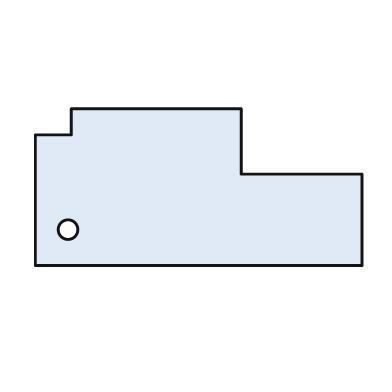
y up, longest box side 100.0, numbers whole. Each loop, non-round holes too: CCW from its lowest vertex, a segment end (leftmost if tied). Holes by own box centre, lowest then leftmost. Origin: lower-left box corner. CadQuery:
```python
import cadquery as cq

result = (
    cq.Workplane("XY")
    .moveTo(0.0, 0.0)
    .lineTo(100.0, 0.0)
    .lineTo(100.0, 28.0)
    .lineTo(63.0, 28.0)
    .lineTo(63.0, 48.0)
    .lineTo(11.0, 48.0)
    .lineTo(11.0, 40.0)
    .lineTo(0.0, 40.0)
    .close()
    .moveTo(10.0, 11.0)
    .circle(3.0)
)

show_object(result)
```